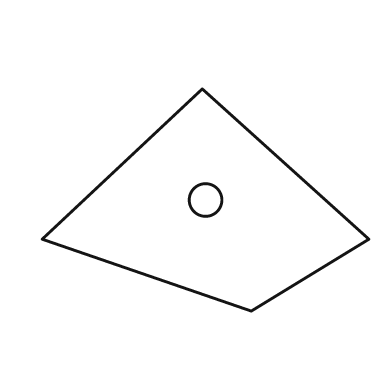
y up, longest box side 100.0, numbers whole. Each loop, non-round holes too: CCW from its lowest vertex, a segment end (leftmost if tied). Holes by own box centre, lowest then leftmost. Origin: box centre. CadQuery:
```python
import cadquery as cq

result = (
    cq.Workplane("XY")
    .moveTo(14.0, -34.0)
    .lineTo(50.0, -12.0)
    .lineTo(-1.0, 34.0)
    .lineTo(-50.0, -12.0)
    .close()
    .moveTo(0.0, 0.0)
    .circle(5.0)
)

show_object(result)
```